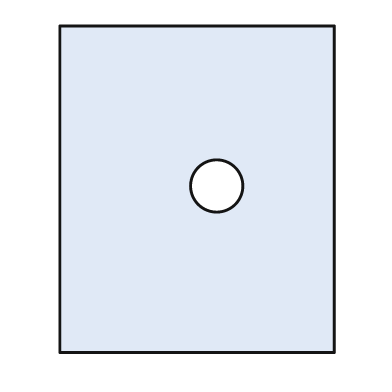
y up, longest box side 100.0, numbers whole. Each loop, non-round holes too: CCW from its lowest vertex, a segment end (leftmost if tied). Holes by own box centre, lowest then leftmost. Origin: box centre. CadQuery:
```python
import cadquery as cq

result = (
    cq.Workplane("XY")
    .moveTo(-42.0, -50.0)
    .lineTo(42.0, -50.0)
    .lineTo(42.0, 50.0)
    .lineTo(-42.0, 50.0)
    .close()
    .moveTo(6.0, 1.0)
    .circle(8.0)
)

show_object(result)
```